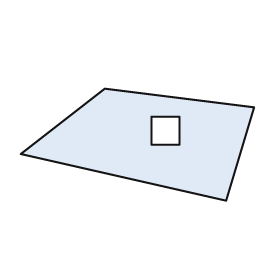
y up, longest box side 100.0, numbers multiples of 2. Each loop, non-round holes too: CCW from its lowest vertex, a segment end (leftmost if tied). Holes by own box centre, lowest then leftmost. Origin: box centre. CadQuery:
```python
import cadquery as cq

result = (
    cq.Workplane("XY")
    .moveTo(38.0, -24.0)
    .lineTo(50.0, 16.0)
    .lineTo(-14.0, 24.0)
    .lineTo(-50.0, -4.0)
    .close()
    .moveTo(6.0, 0.0)
    .lineTo(18.0, 0.0)
    .lineTo(18.0, 12.0)
    .lineTo(6.0, 12.0)
    .close()
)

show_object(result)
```